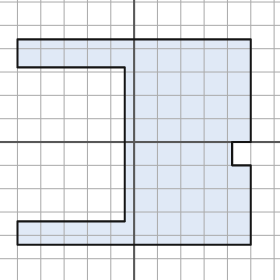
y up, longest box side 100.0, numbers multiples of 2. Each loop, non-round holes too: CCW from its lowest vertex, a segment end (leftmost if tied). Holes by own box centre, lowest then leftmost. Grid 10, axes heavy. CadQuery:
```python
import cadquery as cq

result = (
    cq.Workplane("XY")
    .moveTo(-50.0, -44.0)
    .lineTo(50.0, -44.0)
    .lineTo(50.0, -10.0)
    .lineTo(42.0, -10.0)
    .lineTo(42.0, 0.0)
    .lineTo(50.0, 0.0)
    .lineTo(50.0, 44.0)
    .lineTo(-50.0, 44.0)
    .lineTo(-50.0, 32.0)
    .lineTo(-4.0, 32.0)
    .lineTo(-4.0, -34.0)
    .lineTo(-50.0, -34.0)
    .close()
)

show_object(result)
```